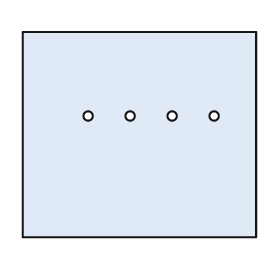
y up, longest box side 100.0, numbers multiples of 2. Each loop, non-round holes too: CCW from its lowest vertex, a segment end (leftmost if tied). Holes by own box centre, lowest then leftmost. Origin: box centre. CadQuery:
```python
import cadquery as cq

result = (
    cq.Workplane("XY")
    .moveTo(-50.0, -44.0)
    .lineTo(50.0, -44.0)
    .lineTo(50.0, 44.0)
    .lineTo(-50.0, 44.0)
    .close()
    .moveTo(-22.0, 8.0)
    .circle(2.0)
    .moveTo(-4.0, 8.0)
    .circle(2.0)
    .moveTo(14.0, 8.0)
    .circle(2.0)
    .moveTo(32.0, 8.0)
    .circle(2.0)
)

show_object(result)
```